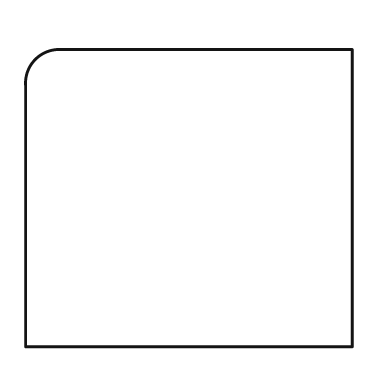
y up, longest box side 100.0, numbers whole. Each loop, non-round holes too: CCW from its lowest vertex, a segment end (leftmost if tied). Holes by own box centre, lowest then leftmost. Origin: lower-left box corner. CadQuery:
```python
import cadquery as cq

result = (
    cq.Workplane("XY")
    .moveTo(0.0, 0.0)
    .lineTo(100.0, 0.0)
    .lineTo(100.0, 91.0)
    .lineTo(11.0, 91.0)
    .threePointArc((3.0, 88.0), (0.0, 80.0))
    .close()
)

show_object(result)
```